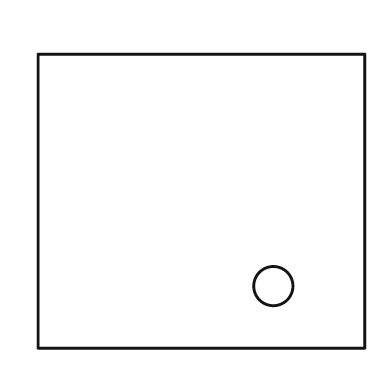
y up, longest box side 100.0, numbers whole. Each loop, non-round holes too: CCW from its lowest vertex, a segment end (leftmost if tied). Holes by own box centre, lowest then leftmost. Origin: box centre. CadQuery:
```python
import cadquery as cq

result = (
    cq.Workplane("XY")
    .moveTo(-50.0, -45.0)
    .lineTo(50.0, -45.0)
    .lineTo(50.0, 45.0)
    .lineTo(-50.0, 45.0)
    .close()
    .moveTo(22.0, -26.0)
    .circle(6.0)
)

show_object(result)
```